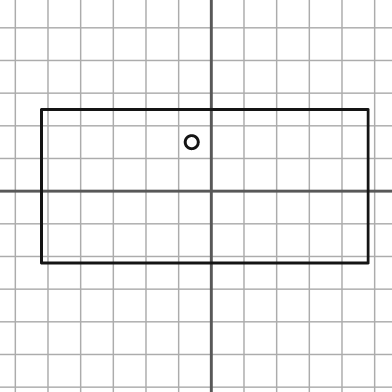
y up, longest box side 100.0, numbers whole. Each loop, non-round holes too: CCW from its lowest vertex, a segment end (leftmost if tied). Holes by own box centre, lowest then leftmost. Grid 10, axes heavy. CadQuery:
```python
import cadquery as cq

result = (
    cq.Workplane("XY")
    .moveTo(-52.0, -22.0)
    .lineTo(48.0, -22.0)
    .lineTo(48.0, 25.0)
    .lineTo(-52.0, 25.0)
    .close()
    .moveTo(-6.0, 15.0)
    .circle(2.0)
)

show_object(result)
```